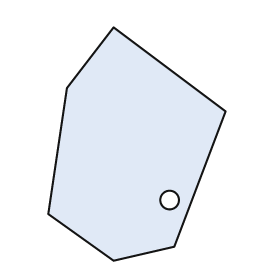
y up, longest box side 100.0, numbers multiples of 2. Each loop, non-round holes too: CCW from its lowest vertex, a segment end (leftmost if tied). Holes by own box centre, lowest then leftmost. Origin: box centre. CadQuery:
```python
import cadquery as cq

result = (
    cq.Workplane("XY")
    .moveTo(-10.0, -50.0)
    .lineTo(16.0, -44.0)
    .lineTo(38.0, 14.0)
    .lineTo(-10.0, 50.0)
    .lineTo(-30.0, 24.0)
    .lineTo(-38.0, -30.0)
    .close()
    .moveTo(14.0, -24.0)
    .circle(4.0)
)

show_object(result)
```